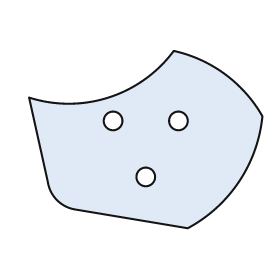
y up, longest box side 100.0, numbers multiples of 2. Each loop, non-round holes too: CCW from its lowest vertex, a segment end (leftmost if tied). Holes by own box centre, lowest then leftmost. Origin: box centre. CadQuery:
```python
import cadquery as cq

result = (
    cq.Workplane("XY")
    .moveTo(18.0, -38.0)
    .threePointArc((40.0, -18.0), (50.0, 10.0))
    .threePointArc((34.0, 28.0), (12.0, 38.0))
    .threePointArc((-16.0, 18.0), (-50.0, 18.0))
    .lineTo(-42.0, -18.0)
    .threePointArc((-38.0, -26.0), (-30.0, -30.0))
    .close()
    .moveTo(0.0, -16.0)
    .circle(4.0)
    .moveTo(-14.0, 8.0)
    .circle(4.0)
    .moveTo(14.0, 8.0)
    .circle(4.0)
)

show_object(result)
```